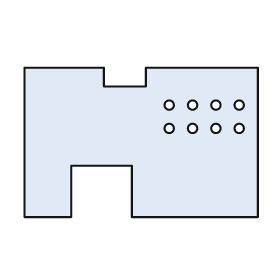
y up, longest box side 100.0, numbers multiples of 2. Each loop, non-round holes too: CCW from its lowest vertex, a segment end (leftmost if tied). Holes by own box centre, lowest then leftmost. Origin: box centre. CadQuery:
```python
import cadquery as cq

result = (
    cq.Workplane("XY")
    .moveTo(-50.0, -32.0)
    .lineTo(-30.0, -32.0)
    .lineTo(-30.0, -10.0)
    .lineTo(-4.0, -10.0)
    .lineTo(-4.0, -32.0)
    .lineTo(50.0, -32.0)
    .lineTo(50.0, 32.0)
    .lineTo(2.0, 32.0)
    .lineTo(2.0, 24.0)
    .lineTo(-16.0, 24.0)
    .lineTo(-16.0, 32.0)
    .lineTo(-50.0, 32.0)
    .close()
    .moveTo(12.0, 6.0)
    .circle(2.0)
    .moveTo(22.0, 6.0)
    .circle(2.0)
    .moveTo(32.0, 6.0)
    .circle(2.0)
    .moveTo(42.0, 6.0)
    .circle(2.0)
    .moveTo(12.0, 16.0)
    .circle(2.0)
    .moveTo(22.0, 16.0)
    .circle(2.0)
    .moveTo(32.0, 16.0)
    .circle(2.0)
    .moveTo(42.0, 16.0)
    .circle(2.0)
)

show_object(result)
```